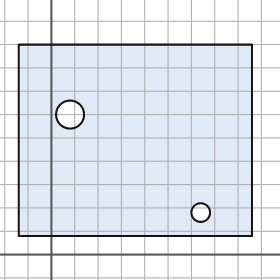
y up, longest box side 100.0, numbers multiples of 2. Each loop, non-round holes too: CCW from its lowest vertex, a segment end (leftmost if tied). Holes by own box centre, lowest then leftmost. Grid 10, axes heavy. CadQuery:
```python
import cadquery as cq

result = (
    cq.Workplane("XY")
    .moveTo(-14.0, 8.0)
    .lineTo(86.0, 8.0)
    .lineTo(86.0, 90.0)
    .lineTo(-14.0, 90.0)
    .close()
    .moveTo(64.0, 18.0)
    .circle(4.0)
    .moveTo(8.0, 60.0)
    .circle(6.0)
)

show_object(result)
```